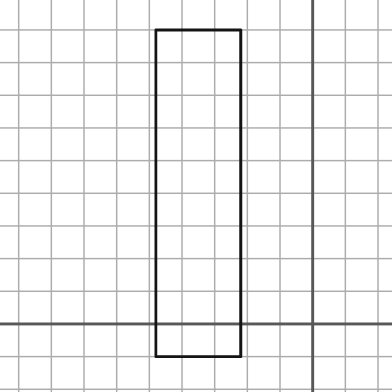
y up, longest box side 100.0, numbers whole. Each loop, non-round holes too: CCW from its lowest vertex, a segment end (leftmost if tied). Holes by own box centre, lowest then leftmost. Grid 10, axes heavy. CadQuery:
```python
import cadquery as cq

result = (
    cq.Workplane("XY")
    .moveTo(-48.0, -10.0)
    .lineTo(-22.0, -10.0)
    .lineTo(-22.0, 90.0)
    .lineTo(-48.0, 90.0)
    .close()
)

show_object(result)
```